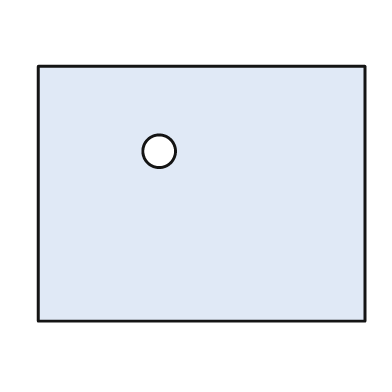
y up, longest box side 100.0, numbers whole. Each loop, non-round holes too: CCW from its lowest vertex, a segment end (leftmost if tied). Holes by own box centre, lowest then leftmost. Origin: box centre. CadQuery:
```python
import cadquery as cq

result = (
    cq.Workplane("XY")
    .moveTo(-50.0, -39.0)
    .lineTo(50.0, -39.0)
    .lineTo(50.0, 39.0)
    .lineTo(-50.0, 39.0)
    .close()
    .moveTo(-13.0, 13.0)
    .circle(5.0)
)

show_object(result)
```